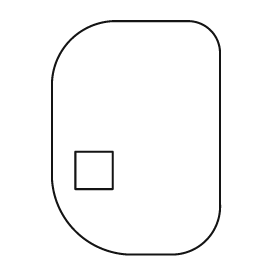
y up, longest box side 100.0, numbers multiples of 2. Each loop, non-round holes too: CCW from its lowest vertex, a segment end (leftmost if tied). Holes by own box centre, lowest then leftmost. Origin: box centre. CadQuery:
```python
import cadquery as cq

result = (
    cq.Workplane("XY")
    .moveTo(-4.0, -50.0)
    .lineTo(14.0, -50.0)
    .threePointArc((30.0, -44.0), (36.0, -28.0))
    .lineTo(36.0, 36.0)
    .threePointArc((32.0, 46.0), (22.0, 50.0))
    .lineTo(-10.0, 50.0)
    .threePointArc((-28.0, 42.0), (-36.0, 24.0))
    .lineTo(-36.0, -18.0)
    .threePointArc((-26.0, -40.0), (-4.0, -50.0))
    .close()
    .moveTo(-26.0, -22.0)
    .lineTo(-10.0, -22.0)
    .lineTo(-10.0, -6.0)
    .lineTo(-26.0, -6.0)
    .close()
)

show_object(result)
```